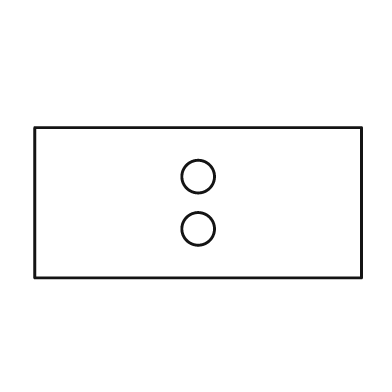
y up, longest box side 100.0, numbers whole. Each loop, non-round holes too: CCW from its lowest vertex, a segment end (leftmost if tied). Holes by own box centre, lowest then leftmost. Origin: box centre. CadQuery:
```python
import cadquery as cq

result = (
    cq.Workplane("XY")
    .moveTo(-50.0, -23.0)
    .lineTo(50.0, -23.0)
    .lineTo(50.0, 23.0)
    .lineTo(-50.0, 23.0)
    .close()
    .moveTo(0.0, -8.0)
    .circle(5.0)
    .moveTo(0.0, 8.0)
    .circle(5.0)
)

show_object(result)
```